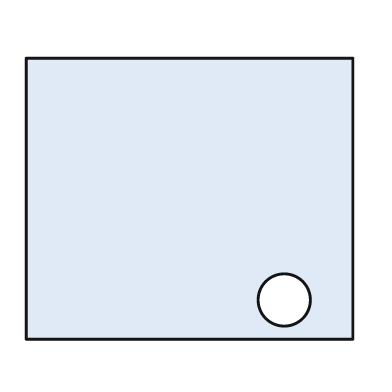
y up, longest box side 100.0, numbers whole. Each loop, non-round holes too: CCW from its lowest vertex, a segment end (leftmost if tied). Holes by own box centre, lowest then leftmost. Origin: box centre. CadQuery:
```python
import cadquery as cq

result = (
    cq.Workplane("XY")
    .moveTo(-50.0, -43.0)
    .lineTo(50.0, -43.0)
    .lineTo(50.0, 43.0)
    .lineTo(-50.0, 43.0)
    .close()
    .moveTo(29.0, -31.0)
    .circle(8.0)
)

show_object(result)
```